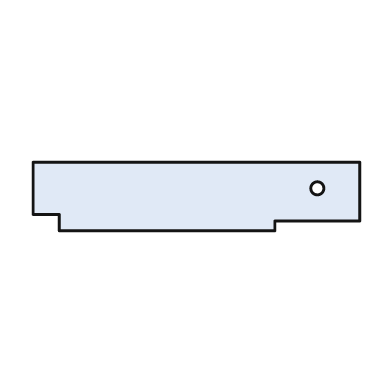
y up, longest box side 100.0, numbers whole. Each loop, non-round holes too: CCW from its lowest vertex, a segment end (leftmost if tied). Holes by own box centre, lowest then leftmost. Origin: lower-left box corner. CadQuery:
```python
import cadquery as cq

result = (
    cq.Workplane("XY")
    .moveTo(8.0, 0.0)
    .lineTo(74.0, 0.0)
    .lineTo(74.0, 3.0)
    .lineTo(100.0, 3.0)
    .lineTo(100.0, 21.0)
    .lineTo(0.0, 21.0)
    .lineTo(0.0, 5.0)
    .lineTo(8.0, 5.0)
    .close()
    .moveTo(87.0, 13.0)
    .circle(2.0)
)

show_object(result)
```